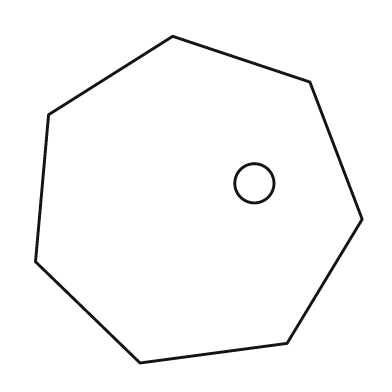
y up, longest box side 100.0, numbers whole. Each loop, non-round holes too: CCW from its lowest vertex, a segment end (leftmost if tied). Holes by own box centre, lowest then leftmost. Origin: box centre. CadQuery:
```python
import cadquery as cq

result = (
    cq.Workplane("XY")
    .moveTo(-18.0, -50.0)
    .lineTo(27.0, -44.0)
    .lineTo(50.0, -6.0)
    .lineTo(34.0, 36.0)
    .lineTo(-8.0, 50.0)
    .lineTo(-46.0, 26.0)
    .lineTo(-50.0, -19.0)
    .close()
    .moveTo(17.0, 5.0)
    .circle(6.0)
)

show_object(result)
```